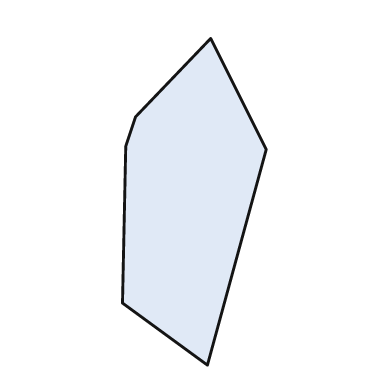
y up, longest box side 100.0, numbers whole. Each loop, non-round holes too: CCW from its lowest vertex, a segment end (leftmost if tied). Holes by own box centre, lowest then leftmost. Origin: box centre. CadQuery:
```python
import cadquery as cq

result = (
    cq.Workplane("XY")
    .moveTo(4.0, -50.0)
    .lineTo(22.0, 16.0)
    .lineTo(5.0, 50.0)
    .lineTo(-18.0, 26.0)
    .lineTo(-21.0, 17.0)
    .lineTo(-22.0, -31.0)
    .close()
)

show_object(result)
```